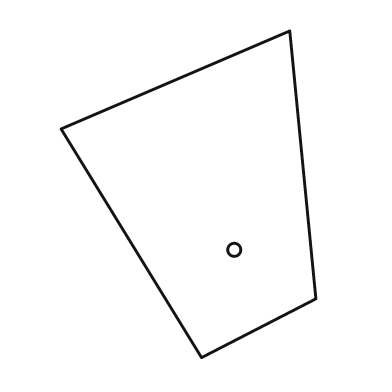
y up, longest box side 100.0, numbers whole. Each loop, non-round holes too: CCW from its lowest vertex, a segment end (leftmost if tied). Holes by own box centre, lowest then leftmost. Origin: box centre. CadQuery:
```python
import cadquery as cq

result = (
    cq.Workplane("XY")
    .moveTo(4.0, -50.0)
    .lineTo(39.0, -32.0)
    .lineTo(31.0, 50.0)
    .lineTo(-39.0, 20.0)
    .close()
    .moveTo(14.0, -17.0)
    .circle(2.0)
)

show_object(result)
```